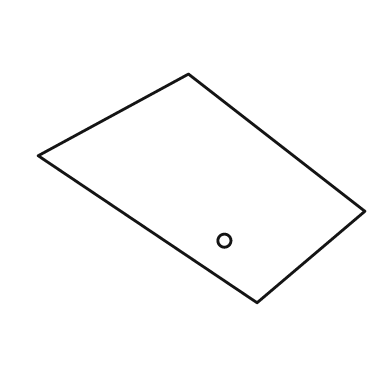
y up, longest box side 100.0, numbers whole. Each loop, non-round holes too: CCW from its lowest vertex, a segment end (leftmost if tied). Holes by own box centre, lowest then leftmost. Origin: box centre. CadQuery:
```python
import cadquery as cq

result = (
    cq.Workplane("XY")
    .moveTo(17.0, -35.0)
    .lineTo(50.0, -7.0)
    .lineTo(-4.0, 35.0)
    .lineTo(-50.0, 10.0)
    .close()
    .moveTo(7.0, -16.0)
    .circle(2.0)
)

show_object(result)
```